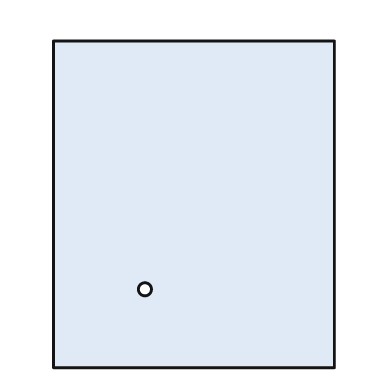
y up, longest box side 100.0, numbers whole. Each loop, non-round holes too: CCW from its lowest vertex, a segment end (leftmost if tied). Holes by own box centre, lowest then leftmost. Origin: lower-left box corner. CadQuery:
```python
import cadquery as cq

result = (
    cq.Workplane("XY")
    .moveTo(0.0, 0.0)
    .lineTo(86.0, 0.0)
    .lineTo(86.0, 100.0)
    .lineTo(0.0, 100.0)
    .close()
    .moveTo(28.0, 24.0)
    .circle(2.0)
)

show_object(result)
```